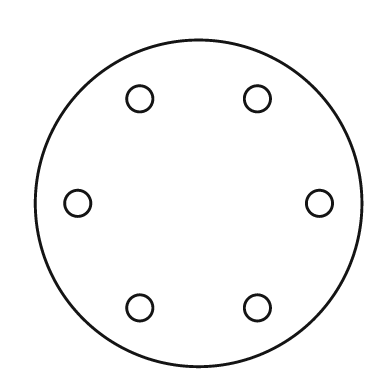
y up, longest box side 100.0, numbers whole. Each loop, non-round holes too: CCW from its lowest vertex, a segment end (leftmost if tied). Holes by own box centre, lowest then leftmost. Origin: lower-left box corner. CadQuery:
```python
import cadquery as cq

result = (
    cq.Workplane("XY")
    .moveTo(50.0, 50.0)
    .circle(50.0)
    .moveTo(32.0, 18.0)
    .circle(4.0)
    .moveTo(68.0, 18.0)
    .circle(4.0)
    .moveTo(13.0, 50.0)
    .circle(4.0)
    .moveTo(87.0, 50.0)
    .circle(4.0)
    .moveTo(32.0, 82.0)
    .circle(4.0)
    .moveTo(68.0, 82.0)
    .circle(4.0)
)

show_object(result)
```